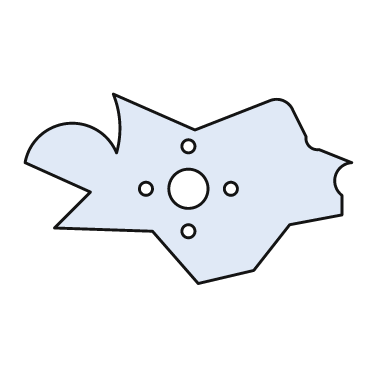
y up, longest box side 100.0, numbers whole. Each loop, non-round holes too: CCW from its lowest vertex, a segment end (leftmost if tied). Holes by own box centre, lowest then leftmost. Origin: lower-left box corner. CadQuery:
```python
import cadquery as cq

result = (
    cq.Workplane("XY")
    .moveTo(53.0, 0.0)
    .lineTo(70.0, 4.0)
    .lineTo(81.0, 18.0)
    .lineTo(97.0, 21.0)
    .lineTo(97.0, 27.0)
    .threePointArc((95.0, 33.0), (100.0, 37.0))
    .lineTo(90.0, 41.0)
    .threePointArc((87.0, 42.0), (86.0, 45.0))
    .lineTo(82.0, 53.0)
    .threePointArc((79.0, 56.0), (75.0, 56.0))
    .lineTo(52.0, 47.0)
    .lineTo(27.0, 58.0)
    .threePointArc((29.0, 49.0), (28.0, 40.0))
    .threePointArc((13.0, 49.0), (0.0, 37.0))
    .lineTo(20.0, 28.0)
    .lineTo(9.0, 17.0)
    .lineTo(39.0, 16.0)
    .close()
    .moveTo(50.0, 16.0)
    .circle(2.0)
    .moveTo(37.0, 29.0)
    .circle(2.0)
    .moveTo(50.0, 29.0)
    .circle(6.0)
    .moveTo(63.0, 29.0)
    .circle(2.0)
    .moveTo(50.0, 42.0)
    .circle(2.0)
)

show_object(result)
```